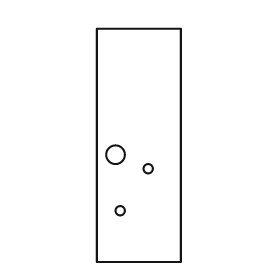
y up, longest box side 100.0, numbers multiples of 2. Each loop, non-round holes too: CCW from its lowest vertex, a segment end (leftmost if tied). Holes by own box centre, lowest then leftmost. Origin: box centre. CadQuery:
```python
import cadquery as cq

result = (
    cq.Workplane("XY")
    .moveTo(-18.0, -50.0)
    .lineTo(18.0, -50.0)
    .lineTo(18.0, 50.0)
    .lineTo(-18.0, 50.0)
    .close()
    .moveTo(-8.0, -28.0)
    .circle(2.0)
    .moveTo(4.0, -10.0)
    .circle(2.0)
    .moveTo(-10.0, -4.0)
    .circle(4.0)
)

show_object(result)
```